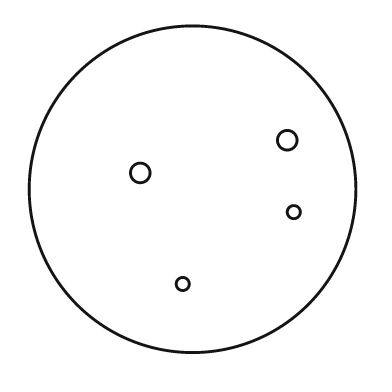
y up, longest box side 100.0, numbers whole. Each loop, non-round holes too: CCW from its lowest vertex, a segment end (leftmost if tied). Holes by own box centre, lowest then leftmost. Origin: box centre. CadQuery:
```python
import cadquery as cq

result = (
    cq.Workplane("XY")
    .moveTo(0.0, 0.0)
    .circle(50.0)
    .moveTo(-3.0, -29.0)
    .circle(2.0)
    .moveTo(31.0, -7.0)
    .circle(2.0)
    .moveTo(-16.0, 5.0)
    .circle(3.0)
    .moveTo(29.0, 15.0)
    .circle(3.0)
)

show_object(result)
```